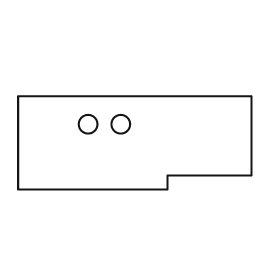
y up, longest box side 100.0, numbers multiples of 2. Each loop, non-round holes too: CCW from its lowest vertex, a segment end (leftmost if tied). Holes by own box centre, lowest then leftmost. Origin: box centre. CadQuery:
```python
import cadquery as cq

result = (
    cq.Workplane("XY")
    .moveTo(-50.0, -20.0)
    .lineTo(14.0, -20.0)
    .lineTo(14.0, -14.0)
    .lineTo(50.0, -14.0)
    .lineTo(50.0, 20.0)
    .lineTo(-50.0, 20.0)
    .close()
    .moveTo(-20.0, 8.0)
    .circle(4.0)
    .moveTo(-6.0, 8.0)
    .circle(4.0)
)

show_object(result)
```